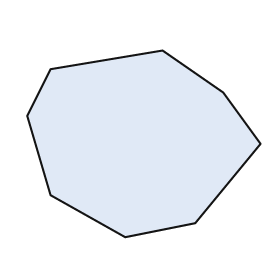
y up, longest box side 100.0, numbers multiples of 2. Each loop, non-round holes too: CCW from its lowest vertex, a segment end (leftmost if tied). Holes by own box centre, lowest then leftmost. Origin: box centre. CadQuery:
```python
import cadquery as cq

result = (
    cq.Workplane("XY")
    .moveTo(-8.0, -40.0)
    .lineTo(22.0, -34.0)
    .lineTo(50.0, 0.0)
    .lineTo(34.0, 22.0)
    .lineTo(8.0, 40.0)
    .lineTo(-40.0, 32.0)
    .lineTo(-50.0, 12.0)
    .lineTo(-40.0, -22.0)
    .close()
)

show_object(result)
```